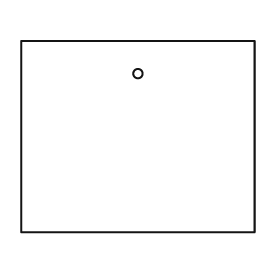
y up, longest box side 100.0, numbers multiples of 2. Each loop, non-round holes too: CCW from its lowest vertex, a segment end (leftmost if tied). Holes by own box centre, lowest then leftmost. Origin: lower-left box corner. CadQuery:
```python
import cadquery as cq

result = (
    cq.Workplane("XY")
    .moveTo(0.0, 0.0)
    .lineTo(100.0, 0.0)
    .lineTo(100.0, 82.0)
    .lineTo(0.0, 82.0)
    .close()
    .moveTo(50.0, 68.0)
    .circle(2.0)
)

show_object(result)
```